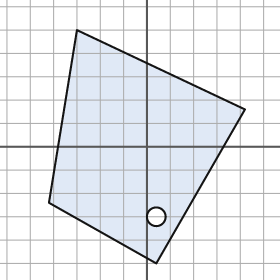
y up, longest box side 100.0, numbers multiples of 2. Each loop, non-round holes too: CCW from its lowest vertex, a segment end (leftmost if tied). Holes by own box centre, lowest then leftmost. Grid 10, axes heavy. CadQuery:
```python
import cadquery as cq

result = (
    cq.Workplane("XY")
    .moveTo(4.0, -50.0)
    .lineTo(42.0, 16.0)
    .lineTo(-30.0, 50.0)
    .lineTo(-42.0, -24.0)
    .close()
    .moveTo(4.0, -30.0)
    .circle(4.0)
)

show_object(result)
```